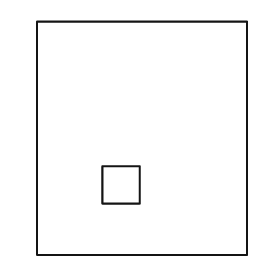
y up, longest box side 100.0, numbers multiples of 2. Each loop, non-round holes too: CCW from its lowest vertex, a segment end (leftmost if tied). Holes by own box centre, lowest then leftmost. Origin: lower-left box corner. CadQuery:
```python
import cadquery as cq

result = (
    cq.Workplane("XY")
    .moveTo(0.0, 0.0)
    .lineTo(90.0, 0.0)
    .lineTo(90.0, 100.0)
    .lineTo(0.0, 100.0)
    .close()
    .moveTo(28.0, 22.0)
    .lineTo(44.0, 22.0)
    .lineTo(44.0, 38.0)
    .lineTo(28.0, 38.0)
    .close()
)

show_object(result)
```